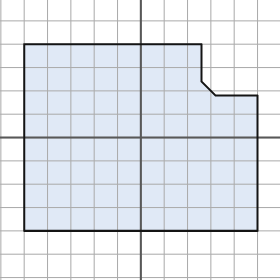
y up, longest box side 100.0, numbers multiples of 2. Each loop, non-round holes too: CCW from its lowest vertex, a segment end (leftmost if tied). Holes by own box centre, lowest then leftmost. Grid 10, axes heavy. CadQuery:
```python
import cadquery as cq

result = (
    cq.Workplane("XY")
    .moveTo(-50.0, -40.0)
    .lineTo(50.0, -40.0)
    .lineTo(50.0, 18.0)
    .lineTo(32.0, 18.0)
    .lineTo(26.0, 24.0)
    .lineTo(26.0, 40.0)
    .lineTo(-50.0, 40.0)
    .close()
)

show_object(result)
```